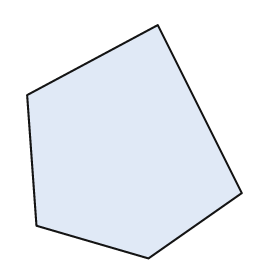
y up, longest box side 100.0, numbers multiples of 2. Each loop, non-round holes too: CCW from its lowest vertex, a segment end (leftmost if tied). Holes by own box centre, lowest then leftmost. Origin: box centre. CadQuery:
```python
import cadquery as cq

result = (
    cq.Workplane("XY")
    .moveTo(6.0, -50.0)
    .lineTo(46.0, -22.0)
    .lineTo(10.0, 50.0)
    .lineTo(-46.0, 20.0)
    .lineTo(-42.0, -36.0)
    .close()
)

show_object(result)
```